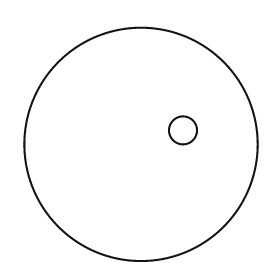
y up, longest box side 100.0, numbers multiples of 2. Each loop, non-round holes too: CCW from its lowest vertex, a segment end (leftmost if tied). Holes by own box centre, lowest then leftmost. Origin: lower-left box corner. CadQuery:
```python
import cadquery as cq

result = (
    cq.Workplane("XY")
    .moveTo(50.0, 50.0)
    .circle(50.0)
    .moveTo(68.0, 56.0)
    .circle(6.0)
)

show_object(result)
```